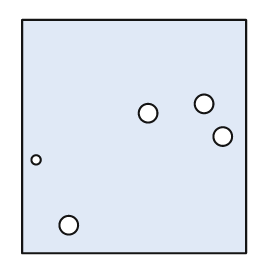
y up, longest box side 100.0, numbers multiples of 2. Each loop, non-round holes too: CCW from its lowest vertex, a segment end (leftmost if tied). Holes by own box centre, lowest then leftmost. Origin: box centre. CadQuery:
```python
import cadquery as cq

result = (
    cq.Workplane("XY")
    .moveTo(-48.0, -50.0)
    .lineTo(48.0, -50.0)
    .lineTo(48.0, 50.0)
    .lineTo(-48.0, 50.0)
    .close()
    .moveTo(-28.0, -38.0)
    .circle(4.0)
    .moveTo(-42.0, -10.0)
    .circle(2.0)
    .moveTo(38.0, 0.0)
    .circle(4.0)
    .moveTo(6.0, 10.0)
    .circle(4.0)
    .moveTo(30.0, 14.0)
    .circle(4.0)
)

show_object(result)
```